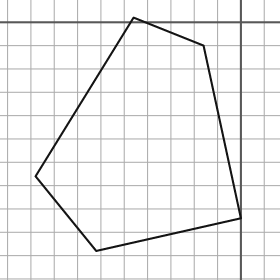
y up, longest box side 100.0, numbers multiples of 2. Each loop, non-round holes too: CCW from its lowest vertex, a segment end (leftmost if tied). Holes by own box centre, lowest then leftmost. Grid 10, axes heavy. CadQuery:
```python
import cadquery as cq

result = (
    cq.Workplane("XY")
    .moveTo(-62.0, -98.0)
    .lineTo(0.0, -84.0)
    .lineTo(-16.0, -10.0)
    .lineTo(-46.0, 2.0)
    .lineTo(-88.0, -66.0)
    .close()
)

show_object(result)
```